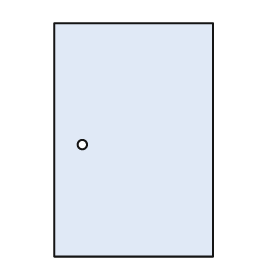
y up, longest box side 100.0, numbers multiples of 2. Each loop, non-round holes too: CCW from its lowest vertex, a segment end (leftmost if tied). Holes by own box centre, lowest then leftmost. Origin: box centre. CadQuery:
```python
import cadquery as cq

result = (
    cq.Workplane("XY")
    .moveTo(-34.0, -50.0)
    .lineTo(34.0, -50.0)
    .lineTo(34.0, 50.0)
    .lineTo(-34.0, 50.0)
    .close()
    .moveTo(-22.0, -2.0)
    .circle(2.0)
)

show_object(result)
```